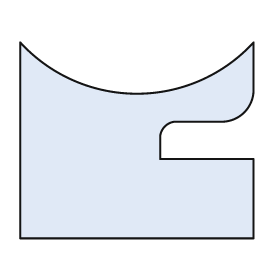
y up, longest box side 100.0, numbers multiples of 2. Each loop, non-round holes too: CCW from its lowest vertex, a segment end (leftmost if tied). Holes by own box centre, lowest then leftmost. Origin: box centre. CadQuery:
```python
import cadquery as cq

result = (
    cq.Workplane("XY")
    .moveTo(-50.0, -42.0)
    .lineTo(50.0, -42.0)
    .lineTo(50.0, -8.0)
    .lineTo(10.0, -8.0)
    .lineTo(10.0, 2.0)
    .threePointArc((12.0, 6.0), (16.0, 8.0))
    .lineTo(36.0, 8.0)
    .threePointArc((46.0, 12.0), (50.0, 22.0))
    .lineTo(50.0, 42.0)
    .threePointArc((0.0, 20.0), (-50.0, 42.0))
    .close()
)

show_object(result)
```